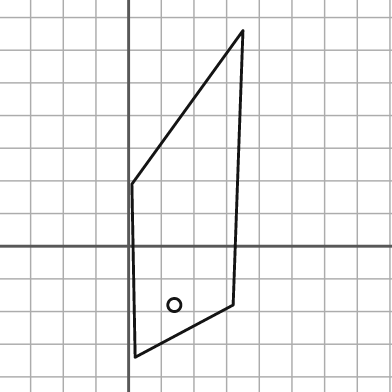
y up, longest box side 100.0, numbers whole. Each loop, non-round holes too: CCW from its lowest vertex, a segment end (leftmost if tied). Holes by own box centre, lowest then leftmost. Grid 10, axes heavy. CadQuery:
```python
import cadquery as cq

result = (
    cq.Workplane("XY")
    .moveTo(2.0, -34.0)
    .lineTo(32.0, -18.0)
    .lineTo(35.0, 66.0)
    .lineTo(1.0, 19.0)
    .close()
    .moveTo(14.0, -18.0)
    .circle(2.0)
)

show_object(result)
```